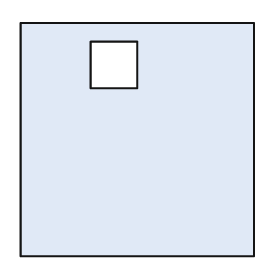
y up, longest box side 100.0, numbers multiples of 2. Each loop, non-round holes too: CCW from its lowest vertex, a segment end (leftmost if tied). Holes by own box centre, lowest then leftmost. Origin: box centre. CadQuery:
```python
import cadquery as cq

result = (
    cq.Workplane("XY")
    .moveTo(-50.0, -50.0)
    .lineTo(50.0, -50.0)
    .lineTo(50.0, 50.0)
    .lineTo(-50.0, 50.0)
    .close()
    .moveTo(-20.0, 22.0)
    .lineTo(0.0, 22.0)
    .lineTo(0.0, 42.0)
    .lineTo(-20.0, 42.0)
    .close()
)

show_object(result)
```